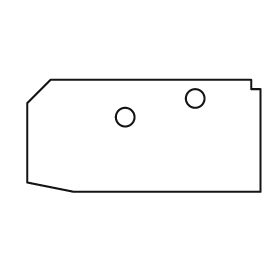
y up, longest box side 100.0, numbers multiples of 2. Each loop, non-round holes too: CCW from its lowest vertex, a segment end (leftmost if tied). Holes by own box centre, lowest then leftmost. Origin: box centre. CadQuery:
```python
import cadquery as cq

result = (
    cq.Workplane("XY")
    .moveTo(-30.0, -24.0)
    .lineTo(50.0, -24.0)
    .lineTo(50.0, 20.0)
    .lineTo(46.0, 20.0)
    .lineTo(46.0, 24.0)
    .lineTo(-40.0, 24.0)
    .lineTo(-50.0, 14.0)
    .lineTo(-50.0, -20.0)
    .close()
    .moveTo(-8.0, 8.0)
    .circle(4.0)
    .moveTo(22.0, 16.0)
    .circle(4.0)
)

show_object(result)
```